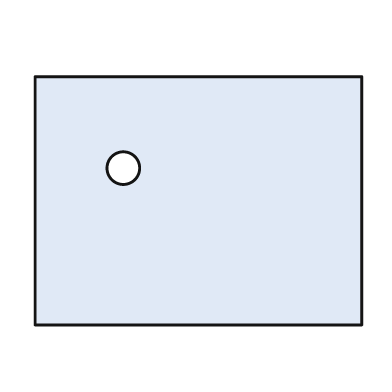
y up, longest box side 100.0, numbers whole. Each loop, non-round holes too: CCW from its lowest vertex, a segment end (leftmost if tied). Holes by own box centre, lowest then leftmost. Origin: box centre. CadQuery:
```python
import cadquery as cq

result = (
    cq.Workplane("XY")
    .moveTo(-50.0, -38.0)
    .lineTo(50.0, -38.0)
    .lineTo(50.0, 38.0)
    .lineTo(-50.0, 38.0)
    .close()
    .moveTo(-23.0, 10.0)
    .circle(5.0)
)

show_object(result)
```